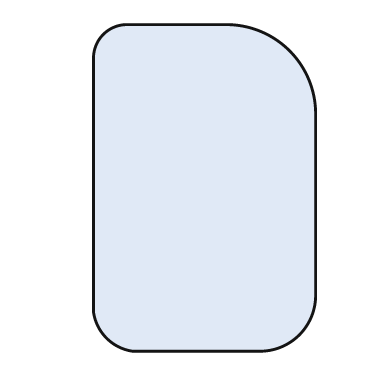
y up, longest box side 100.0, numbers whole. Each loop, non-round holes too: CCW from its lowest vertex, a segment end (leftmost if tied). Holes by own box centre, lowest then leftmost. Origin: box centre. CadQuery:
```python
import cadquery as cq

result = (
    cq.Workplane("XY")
    .moveTo(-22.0, -50.0)
    .lineTo(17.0, -50.0)
    .threePointArc((29.0, -45.0), (34.0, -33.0))
    .lineTo(34.0, 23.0)
    .threePointArc((26.0, 42.0), (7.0, 50.0))
    .lineTo(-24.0, 50.0)
    .threePointArc((-31.0, 47.0), (-34.0, 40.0))
    .lineTo(-34.0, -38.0)
    .threePointArc((-30.0, -46.0), (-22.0, -50.0))
    .close()
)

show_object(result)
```